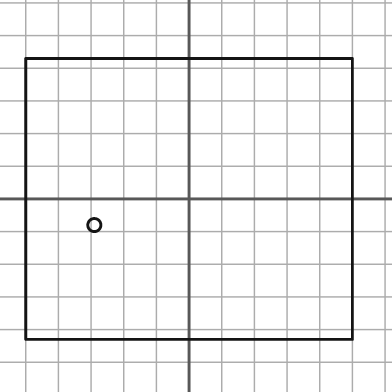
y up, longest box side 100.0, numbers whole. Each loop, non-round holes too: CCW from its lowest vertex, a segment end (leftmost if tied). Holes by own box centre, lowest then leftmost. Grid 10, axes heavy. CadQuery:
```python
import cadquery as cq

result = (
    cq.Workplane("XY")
    .moveTo(-50.0, -43.0)
    .lineTo(50.0, -43.0)
    .lineTo(50.0, 43.0)
    .lineTo(-50.0, 43.0)
    .close()
    .moveTo(-29.0, -8.0)
    .circle(2.0)
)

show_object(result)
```